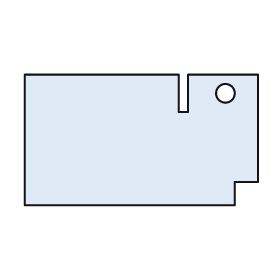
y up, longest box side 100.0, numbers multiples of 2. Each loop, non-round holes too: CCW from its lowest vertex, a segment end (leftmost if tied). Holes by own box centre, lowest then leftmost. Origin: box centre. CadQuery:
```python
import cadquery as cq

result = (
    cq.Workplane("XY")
    .moveTo(-50.0, -28.0)
    .lineTo(40.0, -28.0)
    .lineTo(40.0, -18.0)
    .lineTo(50.0, -18.0)
    .lineTo(50.0, 28.0)
    .lineTo(20.0, 28.0)
    .lineTo(20.0, 12.0)
    .lineTo(16.0, 12.0)
    .lineTo(16.0, 28.0)
    .lineTo(-50.0, 28.0)
    .close()
    .moveTo(36.0, 20.0)
    .circle(4.0)
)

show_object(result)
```